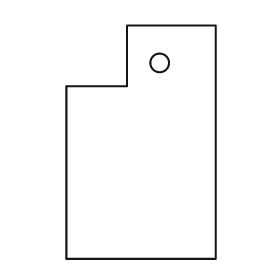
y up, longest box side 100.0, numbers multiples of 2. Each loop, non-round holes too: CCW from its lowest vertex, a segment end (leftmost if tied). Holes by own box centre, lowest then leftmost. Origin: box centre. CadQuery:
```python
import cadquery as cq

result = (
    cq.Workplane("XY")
    .moveTo(-32.0, -50.0)
    .lineTo(32.0, -50.0)
    .lineTo(32.0, 50.0)
    .lineTo(-6.0, 50.0)
    .lineTo(-6.0, 24.0)
    .lineTo(-32.0, 24.0)
    .close()
    .moveTo(8.0, 34.0)
    .circle(4.0)
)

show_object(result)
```